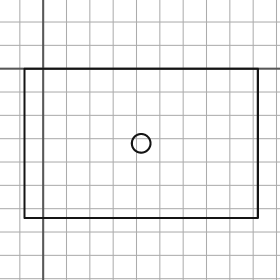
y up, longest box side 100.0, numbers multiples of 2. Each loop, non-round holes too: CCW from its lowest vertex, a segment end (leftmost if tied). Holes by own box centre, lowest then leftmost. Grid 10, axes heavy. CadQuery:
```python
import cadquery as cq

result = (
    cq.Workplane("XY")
    .moveTo(-8.0, -64.0)
    .lineTo(92.0, -64.0)
    .lineTo(92.0, 0.0)
    .lineTo(-8.0, 0.0)
    .close()
    .moveTo(42.0, -32.0)
    .circle(4.0)
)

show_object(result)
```